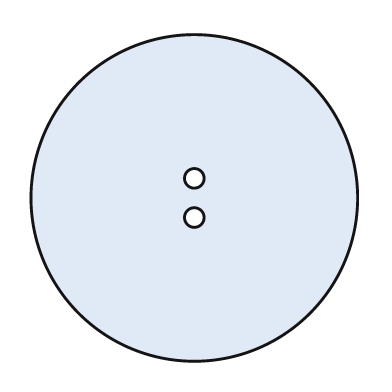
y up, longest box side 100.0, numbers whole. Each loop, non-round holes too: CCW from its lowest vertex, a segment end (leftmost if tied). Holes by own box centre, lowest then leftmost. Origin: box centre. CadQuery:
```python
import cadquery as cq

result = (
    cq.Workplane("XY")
    .moveTo(0.0, 0.0)
    .circle(50.0)
    .moveTo(0.0, -6.0)
    .circle(3.0)
    .moveTo(0.0, 6.0)
    .circle(3.0)
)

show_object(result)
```